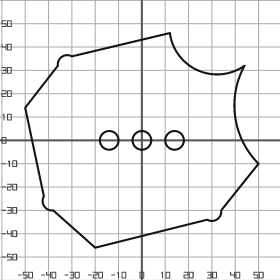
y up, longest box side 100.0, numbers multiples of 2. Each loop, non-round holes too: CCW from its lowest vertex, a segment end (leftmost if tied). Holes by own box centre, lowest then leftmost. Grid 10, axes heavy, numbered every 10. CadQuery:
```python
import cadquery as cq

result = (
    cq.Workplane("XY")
    .moveTo(-20.0, -46.0)
    .lineTo(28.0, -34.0)
    .threePointArc((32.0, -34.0), (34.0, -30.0))
    .lineTo(50.0, -10.0)
    .threePointArc((40.0, 10.0), (44.0, 32.0))
    .threePointArc((24.0, 30.0), (12.0, 46.0))
    .lineTo(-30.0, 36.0)
    .threePointArc((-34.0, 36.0), (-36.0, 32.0))
    .lineTo(-50.0, 14.0)
    .lineTo(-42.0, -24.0)
    .threePointArc((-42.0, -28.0), (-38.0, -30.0))
    .close()
    .moveTo(-14.0, 0.0)
    .circle(4.0)
    .moveTo(0.0, 0.0)
    .circle(4.0)
    .moveTo(14.0, 0.0)
    .circle(4.0)
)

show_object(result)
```